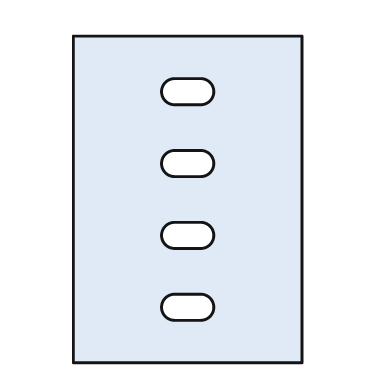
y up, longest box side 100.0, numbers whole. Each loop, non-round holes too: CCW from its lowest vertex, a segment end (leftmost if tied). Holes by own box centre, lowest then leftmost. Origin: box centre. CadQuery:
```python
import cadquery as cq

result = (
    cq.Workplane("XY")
    .moveTo(-35.0, -50.0)
    .lineTo(35.0, -50.0)
    .lineTo(35.0, 50.0)
    .lineTo(-35.0, 50.0)
    .close()
    .moveTo(-4.0, -37.0)
    .lineTo(4.0, -37.0)
    .threePointArc((8.0, -33.0), (4.0, -29.0))
    .lineTo(-4.0, -29.0)
    .threePointArc((-8.0, -33.0), (-4.0, -37.0))
    .close()
    .moveTo(-4.0, -15.0)
    .lineTo(4.0, -15.0)
    .threePointArc((8.0, -11.0), (4.0, -7.0))
    .lineTo(-4.0, -7.0)
    .threePointArc((-8.0, -11.0), (-4.0, -15.0))
    .close()
    .moveTo(-4.0, 7.0)
    .lineTo(4.0, 7.0)
    .threePointArc((8.0, 11.0), (4.0, 15.0))
    .lineTo(-4.0, 15.0)
    .threePointArc((-8.0, 11.0), (-4.0, 7.0))
    .close()
    .moveTo(-4.0, 29.0)
    .lineTo(4.0, 29.0)
    .threePointArc((8.0, 33.0), (4.0, 37.0))
    .lineTo(-4.0, 37.0)
    .threePointArc((-8.0, 33.0), (-4.0, 29.0))
    .close()
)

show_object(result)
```